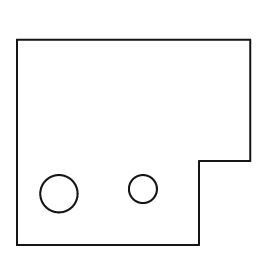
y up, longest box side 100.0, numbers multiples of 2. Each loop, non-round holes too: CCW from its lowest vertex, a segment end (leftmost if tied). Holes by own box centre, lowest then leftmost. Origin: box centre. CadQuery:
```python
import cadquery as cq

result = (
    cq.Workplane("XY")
    .moveTo(-50.0, -44.0)
    .lineTo(28.0, -44.0)
    .lineTo(28.0, -8.0)
    .lineTo(50.0, -8.0)
    .lineTo(50.0, 44.0)
    .lineTo(-50.0, 44.0)
    .close()
    .moveTo(-32.0, -22.0)
    .circle(8.0)
    .moveTo(4.0, -20.0)
    .circle(6.0)
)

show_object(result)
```